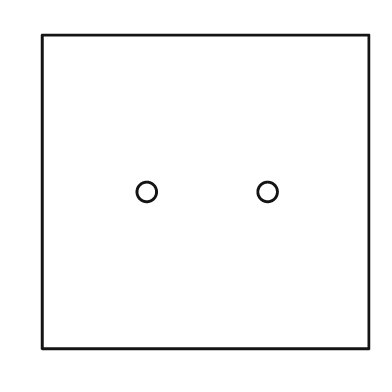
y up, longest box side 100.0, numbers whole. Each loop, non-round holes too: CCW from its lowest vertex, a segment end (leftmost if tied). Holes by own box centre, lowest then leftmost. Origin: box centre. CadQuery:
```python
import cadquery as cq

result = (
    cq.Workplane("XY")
    .moveTo(-50.0, -48.0)
    .lineTo(50.0, -48.0)
    .lineTo(50.0, 48.0)
    .lineTo(-50.0, 48.0)
    .close()
    .moveTo(-18.0, 0.0)
    .circle(3.0)
    .moveTo(19.0, 0.0)
    .circle(3.0)
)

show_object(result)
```